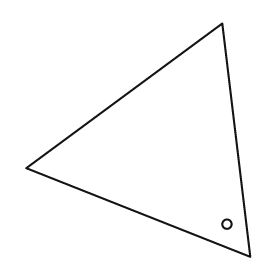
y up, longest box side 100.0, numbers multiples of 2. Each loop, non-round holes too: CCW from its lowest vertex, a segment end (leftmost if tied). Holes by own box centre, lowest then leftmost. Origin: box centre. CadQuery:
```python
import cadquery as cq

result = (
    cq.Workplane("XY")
    .moveTo(48.0, -50.0)
    .lineTo(36.0, 50.0)
    .lineTo(-48.0, -12.0)
    .close()
    .moveTo(38.0, -36.0)
    .circle(2.0)
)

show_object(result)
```